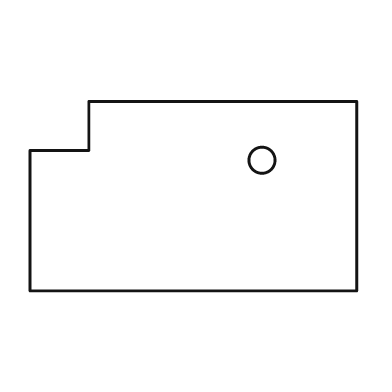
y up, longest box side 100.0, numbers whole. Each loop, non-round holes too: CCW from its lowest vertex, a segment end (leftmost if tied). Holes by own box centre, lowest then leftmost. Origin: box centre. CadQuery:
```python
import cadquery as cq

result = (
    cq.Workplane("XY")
    .moveTo(-50.0, -29.0)
    .lineTo(50.0, -29.0)
    .lineTo(50.0, 29.0)
    .lineTo(-32.0, 29.0)
    .lineTo(-32.0, 14.0)
    .lineTo(-50.0, 14.0)
    .close()
    .moveTo(21.0, 11.0)
    .circle(4.0)
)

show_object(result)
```